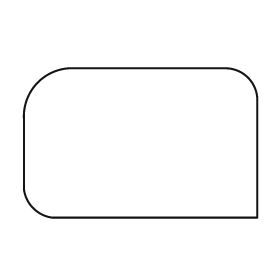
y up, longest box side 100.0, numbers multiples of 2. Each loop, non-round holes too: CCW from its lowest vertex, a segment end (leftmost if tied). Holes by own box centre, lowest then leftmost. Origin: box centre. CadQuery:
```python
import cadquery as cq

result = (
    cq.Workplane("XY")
    .moveTo(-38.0, -32.0)
    .lineTo(50.0, -32.0)
    .lineTo(50.0, 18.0)
    .threePointArc((46.0, 28.0), (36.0, 32.0))
    .lineTo(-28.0, 32.0)
    .threePointArc((-44.0, 26.0), (-50.0, 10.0))
    .lineTo(-50.0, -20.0)
    .threePointArc((-46.0, -28.0), (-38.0, -32.0))
    .close()
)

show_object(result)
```